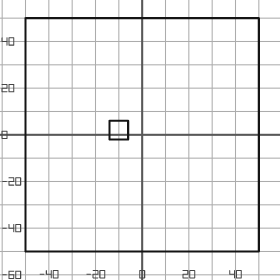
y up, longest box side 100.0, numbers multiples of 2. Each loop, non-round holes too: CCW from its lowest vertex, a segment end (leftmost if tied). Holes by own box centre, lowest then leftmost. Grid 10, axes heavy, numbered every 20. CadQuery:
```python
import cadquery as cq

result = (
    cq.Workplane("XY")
    .moveTo(-50.0, -50.0)
    .lineTo(50.0, -50.0)
    .lineTo(50.0, 50.0)
    .lineTo(-50.0, 50.0)
    .close()
    .moveTo(-14.0, -2.0)
    .lineTo(-6.0, -2.0)
    .lineTo(-6.0, 6.0)
    .lineTo(-14.0, 6.0)
    .close()
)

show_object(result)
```